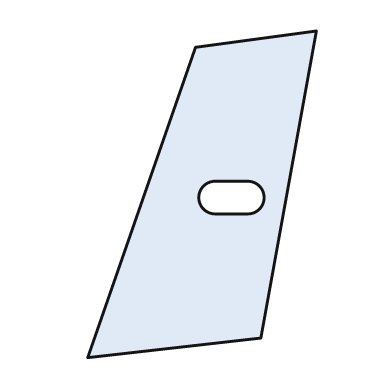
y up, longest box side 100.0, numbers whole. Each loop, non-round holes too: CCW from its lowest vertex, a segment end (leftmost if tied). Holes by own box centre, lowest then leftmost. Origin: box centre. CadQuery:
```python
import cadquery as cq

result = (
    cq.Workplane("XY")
    .moveTo(-35.0, -50.0)
    .lineTo(18.0, -44.0)
    .lineTo(35.0, 50.0)
    .lineTo(-2.0, 45.0)
    .close()
    .moveTo(4.0, -6.0)
    .lineTo(14.0, -6.0)
    .threePointArc((19.0, -1.0), (14.0, 4.0))
    .lineTo(4.0, 4.0)
    .threePointArc((-1.0, -1.0), (4.0, -6.0))
    .close()
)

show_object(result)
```